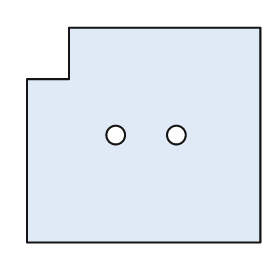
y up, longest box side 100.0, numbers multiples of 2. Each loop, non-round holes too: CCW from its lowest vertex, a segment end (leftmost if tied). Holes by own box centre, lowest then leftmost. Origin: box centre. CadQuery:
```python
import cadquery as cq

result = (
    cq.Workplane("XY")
    .moveTo(-50.0, -46.0)
    .lineTo(50.0, -46.0)
    .lineTo(50.0, 46.0)
    .lineTo(-32.0, 46.0)
    .lineTo(-32.0, 24.0)
    .lineTo(-50.0, 24.0)
    .close()
    .moveTo(-12.0, 0.0)
    .circle(4.0)
    .moveTo(14.0, 0.0)
    .circle(4.0)
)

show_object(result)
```